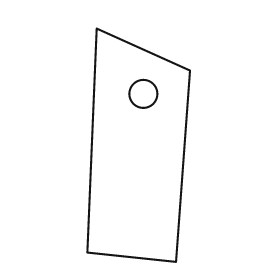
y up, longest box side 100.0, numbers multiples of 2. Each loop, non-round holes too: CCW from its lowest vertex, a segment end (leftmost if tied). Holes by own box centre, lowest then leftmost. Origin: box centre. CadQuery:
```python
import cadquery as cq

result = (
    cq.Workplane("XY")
    .moveTo(16.0, -50.0)
    .lineTo(22.0, 32.0)
    .lineTo(-18.0, 50.0)
    .lineTo(-22.0, -46.0)
    .close()
    .moveTo(2.0, 22.0)
    .circle(6.0)
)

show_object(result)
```